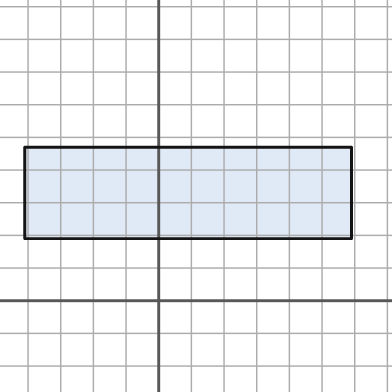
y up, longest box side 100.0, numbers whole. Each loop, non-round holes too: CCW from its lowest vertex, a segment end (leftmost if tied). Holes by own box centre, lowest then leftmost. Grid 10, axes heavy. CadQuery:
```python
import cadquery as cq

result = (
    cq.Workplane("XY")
    .moveTo(-41.0, 19.0)
    .lineTo(59.0, 19.0)
    .lineTo(59.0, 47.0)
    .lineTo(-41.0, 47.0)
    .close()
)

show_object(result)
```